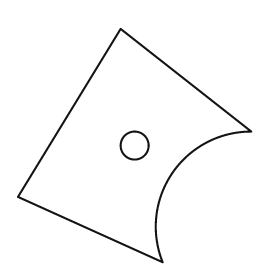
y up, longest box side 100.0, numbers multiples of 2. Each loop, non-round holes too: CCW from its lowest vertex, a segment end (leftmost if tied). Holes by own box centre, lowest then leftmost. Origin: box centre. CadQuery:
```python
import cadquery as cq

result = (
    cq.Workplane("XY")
    .moveTo(12.0, -50.0)
    .threePointArc((16.0, -12.0), (50.0, 6.0))
    .lineTo(-6.0, 50.0)
    .lineTo(-50.0, -22.0)
    .close()
    .moveTo(0.0, 0.0)
    .circle(6.0)
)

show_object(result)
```